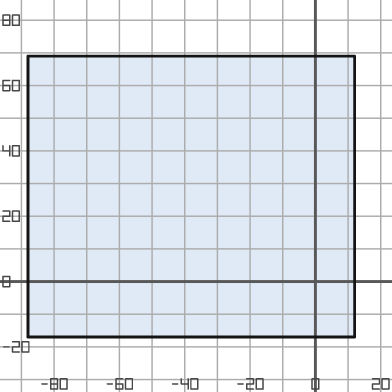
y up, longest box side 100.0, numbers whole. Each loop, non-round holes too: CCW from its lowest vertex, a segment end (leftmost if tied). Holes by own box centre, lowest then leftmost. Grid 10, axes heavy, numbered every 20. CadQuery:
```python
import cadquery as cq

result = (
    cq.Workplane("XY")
    .moveTo(-88.0, -17.0)
    .lineTo(12.0, -17.0)
    .lineTo(12.0, 69.0)
    .lineTo(-88.0, 69.0)
    .close()
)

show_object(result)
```